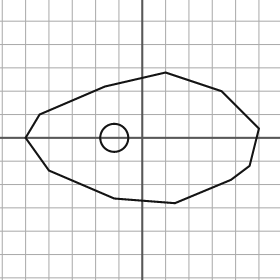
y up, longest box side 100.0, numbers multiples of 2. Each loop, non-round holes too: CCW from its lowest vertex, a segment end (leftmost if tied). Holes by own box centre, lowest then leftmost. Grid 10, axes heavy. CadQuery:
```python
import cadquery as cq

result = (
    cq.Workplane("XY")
    .moveTo(14.0, -28.0)
    .lineTo(38.0, -18.0)
    .lineTo(46.0, -12.0)
    .lineTo(50.0, 4.0)
    .lineTo(34.0, 20.0)
    .lineTo(10.0, 28.0)
    .lineTo(-16.0, 22.0)
    .lineTo(-44.0, 10.0)
    .lineTo(-50.0, 0.0)
    .lineTo(-40.0, -14.0)
    .lineTo(-12.0, -26.0)
    .close()
    .moveTo(-12.0, 0.0)
    .circle(6.0)
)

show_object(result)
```